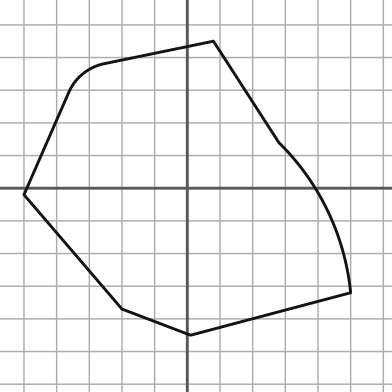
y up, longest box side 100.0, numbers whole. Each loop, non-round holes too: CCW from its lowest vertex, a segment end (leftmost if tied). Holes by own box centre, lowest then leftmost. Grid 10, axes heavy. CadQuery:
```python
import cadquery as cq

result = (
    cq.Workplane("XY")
    .moveTo(1.0, -45.0)
    .lineTo(50.0, -32.0)
    .threePointArc((43.0, -7.0), (28.0, 14.0))
    .lineTo(8.0, 45.0)
    .lineTo(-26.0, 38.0)
    .threePointArc((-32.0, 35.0), (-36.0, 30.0))
    .lineTo(-50.0, -2.0)
    .lineTo(-20.0, -37.0)
    .close()
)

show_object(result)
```